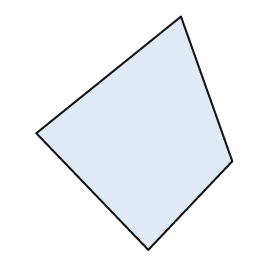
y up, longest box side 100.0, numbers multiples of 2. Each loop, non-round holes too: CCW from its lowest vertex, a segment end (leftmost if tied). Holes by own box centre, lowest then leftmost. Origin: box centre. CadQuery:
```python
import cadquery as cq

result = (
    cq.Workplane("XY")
    .moveTo(6.0, -50.0)
    .lineTo(42.0, -12.0)
    .lineTo(20.0, 50.0)
    .lineTo(-42.0, 0.0)
    .close()
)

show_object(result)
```